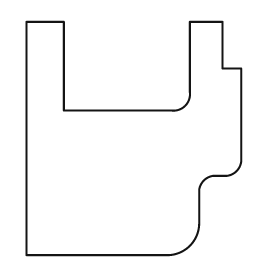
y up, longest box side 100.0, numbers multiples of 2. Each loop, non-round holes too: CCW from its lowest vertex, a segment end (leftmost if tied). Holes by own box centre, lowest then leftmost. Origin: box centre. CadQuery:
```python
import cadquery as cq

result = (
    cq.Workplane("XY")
    .moveTo(-46.0, -50.0)
    .lineTo(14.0, -50.0)
    .threePointArc((24.0, -46.0), (28.0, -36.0))
    .lineTo(28.0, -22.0)
    .threePointArc((30.0, -18.0), (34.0, -16.0))
    .lineTo(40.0, -16.0)
    .threePointArc((44.0, -14.0), (46.0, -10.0))
    .lineTo(46.0, 30.0)
    .lineTo(38.0, 30.0)
    .lineTo(38.0, 50.0)
    .lineTo(24.0, 50.0)
    .lineTo(24.0, 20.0)
    .threePointArc((22.0, 14.0), (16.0, 12.0))
    .lineTo(-30.0, 12.0)
    .lineTo(-30.0, 50.0)
    .lineTo(-46.0, 50.0)
    .close()
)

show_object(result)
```